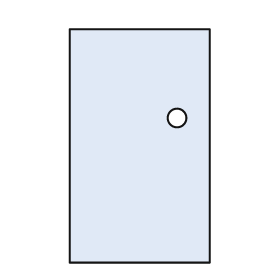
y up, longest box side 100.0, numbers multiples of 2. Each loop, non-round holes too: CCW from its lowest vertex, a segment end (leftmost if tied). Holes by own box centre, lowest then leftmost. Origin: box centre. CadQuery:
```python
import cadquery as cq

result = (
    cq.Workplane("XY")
    .moveTo(-30.0, -50.0)
    .lineTo(30.0, -50.0)
    .lineTo(30.0, 50.0)
    .lineTo(-30.0, 50.0)
    .close()
    .moveTo(16.0, 12.0)
    .circle(4.0)
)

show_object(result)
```